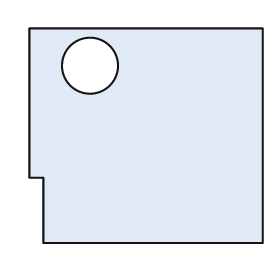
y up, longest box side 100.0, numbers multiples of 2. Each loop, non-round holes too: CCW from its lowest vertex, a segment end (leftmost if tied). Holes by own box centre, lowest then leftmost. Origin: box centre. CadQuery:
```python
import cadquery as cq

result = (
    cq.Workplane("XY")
    .moveTo(-44.0, -46.0)
    .lineTo(50.0, -46.0)
    .lineTo(50.0, 46.0)
    .lineTo(-50.0, 46.0)
    .lineTo(-50.0, -18.0)
    .lineTo(-44.0, -18.0)
    .close()
    .moveTo(-24.0, 30.0)
    .circle(12.0)
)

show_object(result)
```